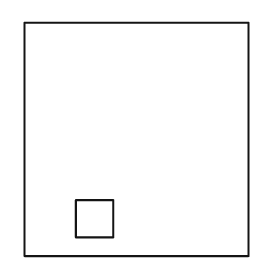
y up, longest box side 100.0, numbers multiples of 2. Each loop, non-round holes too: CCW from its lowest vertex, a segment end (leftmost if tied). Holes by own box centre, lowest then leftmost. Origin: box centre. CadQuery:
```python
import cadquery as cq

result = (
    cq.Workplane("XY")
    .moveTo(-48.0, -50.0)
    .lineTo(48.0, -50.0)
    .lineTo(48.0, 50.0)
    .lineTo(-48.0, 50.0)
    .close()
    .moveTo(-26.0, -42.0)
    .lineTo(-10.0, -42.0)
    .lineTo(-10.0, -26.0)
    .lineTo(-26.0, -26.0)
    .close()
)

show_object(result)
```